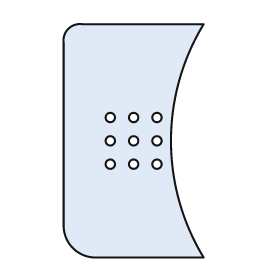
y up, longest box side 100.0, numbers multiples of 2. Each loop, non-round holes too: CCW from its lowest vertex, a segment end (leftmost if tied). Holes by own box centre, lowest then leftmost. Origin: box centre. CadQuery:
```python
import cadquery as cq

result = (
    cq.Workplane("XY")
    .moveTo(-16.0, -50.0)
    .lineTo(30.0, -50.0)
    .threePointArc((16.0, 0.0), (30.0, 50.0))
    .lineTo(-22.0, 50.0)
    .threePointArc((-28.0, 48.0), (-30.0, 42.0))
    .lineTo(-30.0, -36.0)
    .threePointArc((-26.0, -46.0), (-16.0, -50.0))
    .close()
    .moveTo(-10.0, -10.0)
    .circle(2.0)
    .moveTo(0.0, -10.0)
    .circle(2.0)
    .moveTo(10.0, -10.0)
    .circle(2.0)
    .moveTo(-10.0, 0.0)
    .circle(2.0)
    .moveTo(0.0, 0.0)
    .circle(2.0)
    .moveTo(10.0, 0.0)
    .circle(2.0)
    .moveTo(-10.0, 10.0)
    .circle(2.0)
    .moveTo(0.0, 10.0)
    .circle(2.0)
    .moveTo(10.0, 10.0)
    .circle(2.0)
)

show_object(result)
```